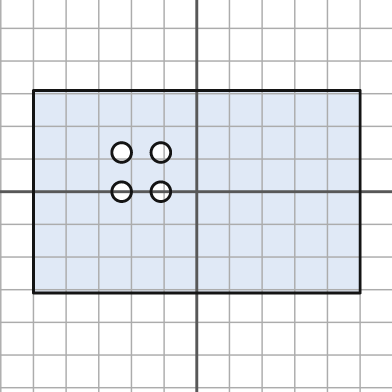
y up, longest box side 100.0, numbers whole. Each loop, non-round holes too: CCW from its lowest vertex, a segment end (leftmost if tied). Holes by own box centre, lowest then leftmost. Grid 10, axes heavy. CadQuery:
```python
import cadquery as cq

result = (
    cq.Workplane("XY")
    .moveTo(-50.0, -31.0)
    .lineTo(50.0, -31.0)
    .lineTo(50.0, 31.0)
    .lineTo(-50.0, 31.0)
    .close()
    .moveTo(-23.0, 0.0)
    .circle(3.0)
    .moveTo(-11.0, 0.0)
    .circle(3.0)
    .moveTo(-23.0, 12.0)
    .circle(3.0)
    .moveTo(-11.0, 12.0)
    .circle(3.0)
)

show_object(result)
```